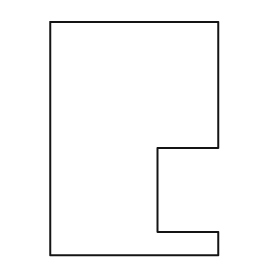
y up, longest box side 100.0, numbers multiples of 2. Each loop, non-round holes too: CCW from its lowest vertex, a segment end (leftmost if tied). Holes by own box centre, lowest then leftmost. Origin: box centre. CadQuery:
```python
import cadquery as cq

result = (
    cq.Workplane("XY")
    .moveTo(-36.0, -50.0)
    .lineTo(36.0, -50.0)
    .lineTo(36.0, -40.0)
    .lineTo(10.0, -40.0)
    .lineTo(10.0, -4.0)
    .lineTo(36.0, -4.0)
    .lineTo(36.0, 50.0)
    .lineTo(-36.0, 50.0)
    .close()
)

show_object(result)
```